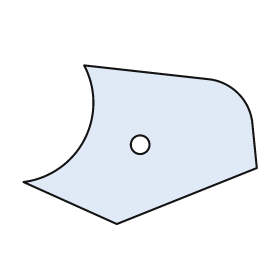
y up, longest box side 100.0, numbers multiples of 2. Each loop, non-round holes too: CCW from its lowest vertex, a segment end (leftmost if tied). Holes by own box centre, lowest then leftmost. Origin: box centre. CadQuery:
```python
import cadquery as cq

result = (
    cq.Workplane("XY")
    .moveTo(-10.0, -34.0)
    .lineTo(50.0, -10.0)
    .lineTo(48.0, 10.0)
    .threePointArc((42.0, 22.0), (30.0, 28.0))
    .lineTo(-24.0, 34.0)
    .threePointArc((-24.0, 2.0), (-50.0, -16.0))
    .close()
    .moveTo(0.0, 0.0)
    .circle(4.0)
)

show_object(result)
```